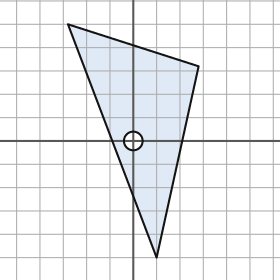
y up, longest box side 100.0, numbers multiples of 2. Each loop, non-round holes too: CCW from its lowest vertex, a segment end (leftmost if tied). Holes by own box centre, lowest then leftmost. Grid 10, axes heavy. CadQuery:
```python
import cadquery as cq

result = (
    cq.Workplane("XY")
    .moveTo(10.0, -50.0)
    .lineTo(28.0, 32.0)
    .lineTo(-28.0, 50.0)
    .close()
    .moveTo(0.0, 0.0)
    .circle(4.0)
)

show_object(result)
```